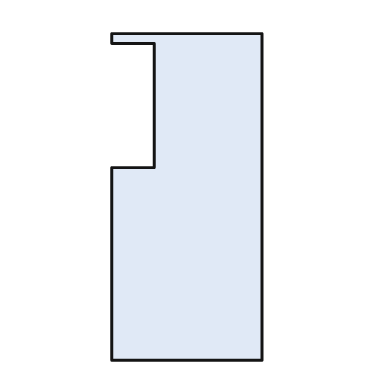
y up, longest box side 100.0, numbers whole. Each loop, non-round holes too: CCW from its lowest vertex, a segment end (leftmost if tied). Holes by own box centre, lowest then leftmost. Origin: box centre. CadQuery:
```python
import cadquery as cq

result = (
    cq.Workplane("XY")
    .moveTo(-23.0, -50.0)
    .lineTo(23.0, -50.0)
    .lineTo(23.0, 50.0)
    .lineTo(-23.0, 50.0)
    .lineTo(-23.0, 47.0)
    .lineTo(-10.0, 47.0)
    .lineTo(-10.0, 9.0)
    .lineTo(-23.0, 9.0)
    .close()
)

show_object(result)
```